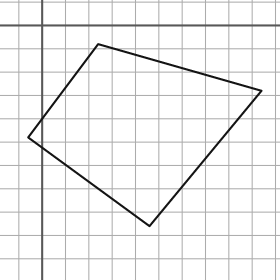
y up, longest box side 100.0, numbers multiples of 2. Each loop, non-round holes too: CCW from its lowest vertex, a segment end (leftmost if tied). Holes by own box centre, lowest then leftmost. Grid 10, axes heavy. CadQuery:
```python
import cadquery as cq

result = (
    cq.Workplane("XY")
    .moveTo(46.0, -86.0)
    .lineTo(94.0, -28.0)
    .lineTo(24.0, -8.0)
    .lineTo(-6.0, -48.0)
    .close()
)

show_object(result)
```